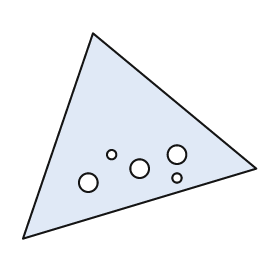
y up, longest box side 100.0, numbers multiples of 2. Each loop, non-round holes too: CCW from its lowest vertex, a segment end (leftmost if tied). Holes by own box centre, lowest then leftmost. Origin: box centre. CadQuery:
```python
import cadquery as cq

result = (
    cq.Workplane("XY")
    .moveTo(-50.0, -44.0)
    .lineTo(50.0, -14.0)
    .lineTo(-20.0, 44.0)
    .close()
    .moveTo(-22.0, -20.0)
    .circle(4.0)
    .moveTo(16.0, -18.0)
    .circle(2.0)
    .moveTo(0.0, -14.0)
    .circle(4.0)
    .moveTo(-12.0, -8.0)
    .circle(2.0)
    .moveTo(16.0, -8.0)
    .circle(4.0)
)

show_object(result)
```